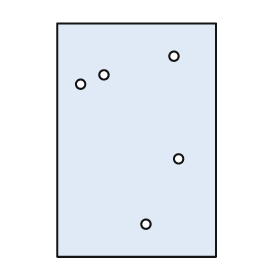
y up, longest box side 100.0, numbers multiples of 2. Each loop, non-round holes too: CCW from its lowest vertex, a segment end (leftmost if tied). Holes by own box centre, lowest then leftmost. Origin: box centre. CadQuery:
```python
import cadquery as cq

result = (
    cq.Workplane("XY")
    .moveTo(-34.0, -50.0)
    .lineTo(34.0, -50.0)
    .lineTo(34.0, 50.0)
    .lineTo(-34.0, 50.0)
    .close()
    .moveTo(4.0, -36.0)
    .circle(2.0)
    .moveTo(18.0, -8.0)
    .circle(2.0)
    .moveTo(-24.0, 24.0)
    .circle(2.0)
    .moveTo(-14.0, 28.0)
    .circle(2.0)
    .moveTo(16.0, 36.0)
    .circle(2.0)
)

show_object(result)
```